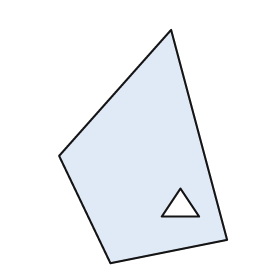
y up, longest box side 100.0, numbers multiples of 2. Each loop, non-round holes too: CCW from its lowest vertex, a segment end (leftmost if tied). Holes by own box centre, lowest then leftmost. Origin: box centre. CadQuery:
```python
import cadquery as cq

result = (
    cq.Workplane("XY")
    .moveTo(-14.0, -50.0)
    .lineTo(36.0, -40.0)
    .lineTo(12.0, 50.0)
    .lineTo(-36.0, -4.0)
    .close()
    .moveTo(8.0, -30.0)
    .lineTo(24.0, -30.0)
    .lineTo(16.0, -18.0)
    .close()
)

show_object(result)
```